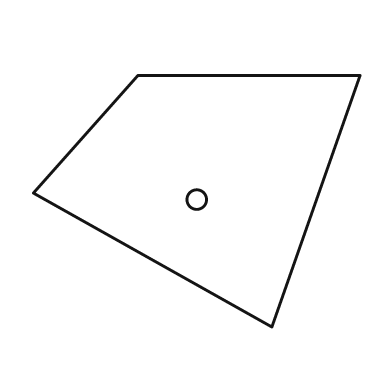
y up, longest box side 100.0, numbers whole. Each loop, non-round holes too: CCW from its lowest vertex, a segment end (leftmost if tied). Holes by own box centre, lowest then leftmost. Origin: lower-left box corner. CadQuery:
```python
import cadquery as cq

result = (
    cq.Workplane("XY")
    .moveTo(73.0, 0.0)
    .lineTo(100.0, 77.0)
    .lineTo(32.0, 77.0)
    .lineTo(0.0, 41.0)
    .close()
    .moveTo(50.0, 39.0)
    .circle(3.0)
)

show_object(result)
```